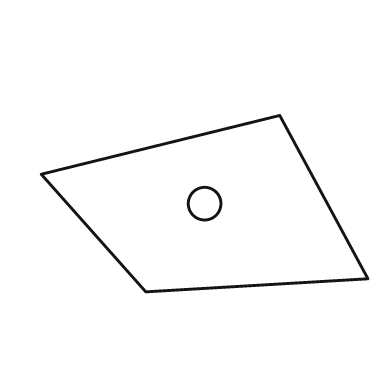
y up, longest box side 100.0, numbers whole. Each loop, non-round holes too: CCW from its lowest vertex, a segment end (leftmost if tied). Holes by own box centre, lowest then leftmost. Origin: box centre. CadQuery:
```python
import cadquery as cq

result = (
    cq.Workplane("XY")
    .moveTo(-18.0, -27.0)
    .lineTo(50.0, -23.0)
    .lineTo(23.0, 27.0)
    .lineTo(-50.0, 9.0)
    .close()
    .moveTo(0.0, 0.0)
    .circle(5.0)
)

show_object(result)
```